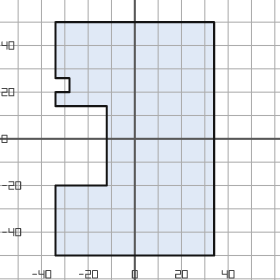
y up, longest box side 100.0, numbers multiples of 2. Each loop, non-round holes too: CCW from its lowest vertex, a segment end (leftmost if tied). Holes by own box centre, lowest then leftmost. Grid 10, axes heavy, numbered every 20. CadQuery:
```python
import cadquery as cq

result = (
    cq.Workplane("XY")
    .moveTo(-34.0, -50.0)
    .lineTo(34.0, -50.0)
    .lineTo(34.0, 50.0)
    .lineTo(-34.0, 50.0)
    .lineTo(-34.0, 26.0)
    .lineTo(-28.0, 26.0)
    .lineTo(-28.0, 20.0)
    .lineTo(-34.0, 20.0)
    .lineTo(-34.0, 14.0)
    .lineTo(-12.0, 14.0)
    .lineTo(-12.0, -20.0)
    .lineTo(-34.0, -20.0)
    .close()
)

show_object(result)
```